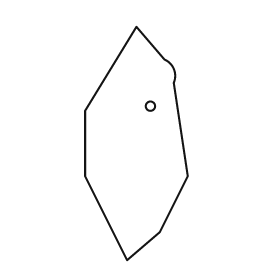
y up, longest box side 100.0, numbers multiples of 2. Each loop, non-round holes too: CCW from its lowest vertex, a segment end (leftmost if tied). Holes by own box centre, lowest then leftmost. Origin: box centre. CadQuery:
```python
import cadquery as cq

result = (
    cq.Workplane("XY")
    .moveTo(-4.0, -50.0)
    .lineTo(10.0, -38.0)
    .lineTo(22.0, -14.0)
    .lineTo(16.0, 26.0)
    .threePointArc((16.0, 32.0), (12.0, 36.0))
    .lineTo(0.0, 50.0)
    .lineTo(-22.0, 14.0)
    .lineTo(-22.0, -14.0)
    .close()
    .moveTo(6.0, 16.0)
    .circle(2.0)
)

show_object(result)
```